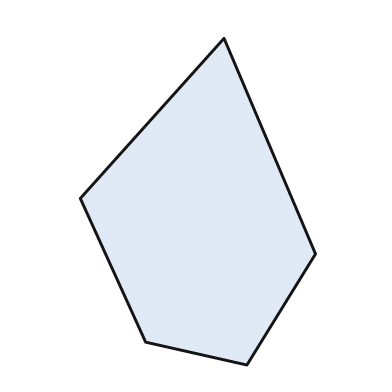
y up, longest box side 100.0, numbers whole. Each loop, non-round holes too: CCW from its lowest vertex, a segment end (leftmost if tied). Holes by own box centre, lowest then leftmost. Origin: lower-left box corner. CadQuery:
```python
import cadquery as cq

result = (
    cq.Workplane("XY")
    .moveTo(51.0, 0.0)
    .lineTo(72.0, 34.0)
    .lineTo(44.0, 100.0)
    .lineTo(0.0, 51.0)
    .lineTo(20.0, 7.0)
    .close()
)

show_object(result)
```